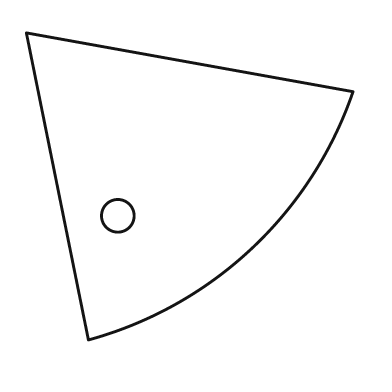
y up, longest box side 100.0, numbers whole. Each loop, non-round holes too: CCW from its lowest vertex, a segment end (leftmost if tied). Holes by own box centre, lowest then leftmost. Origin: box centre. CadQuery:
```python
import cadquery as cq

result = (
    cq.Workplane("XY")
    .moveTo(-31.0, -47.0)
    .threePointArc((19.0, -19.0), (50.0, 29.0))
    .lineTo(-50.0, 47.0)
    .close()
    .moveTo(-22.0, -9.0)
    .circle(5.0)
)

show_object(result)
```